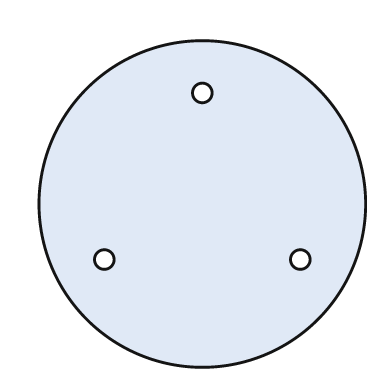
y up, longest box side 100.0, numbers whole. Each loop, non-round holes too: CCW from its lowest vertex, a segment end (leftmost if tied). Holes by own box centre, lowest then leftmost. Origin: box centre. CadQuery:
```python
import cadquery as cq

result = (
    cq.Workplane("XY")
    .moveTo(0.0, 0.0)
    .circle(50.0)
    .moveTo(-30.0, -17.0)
    .circle(3.0)
    .moveTo(30.0, -17.0)
    .circle(3.0)
    .moveTo(0.0, 34.0)
    .circle(3.0)
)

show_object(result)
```